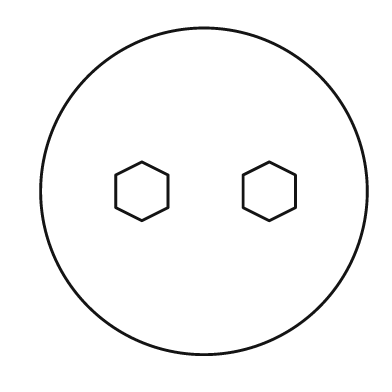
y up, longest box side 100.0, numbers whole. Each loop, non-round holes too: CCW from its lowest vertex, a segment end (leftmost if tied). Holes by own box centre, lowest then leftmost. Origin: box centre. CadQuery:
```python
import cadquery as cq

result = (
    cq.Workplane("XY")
    .moveTo(0.0, 0.0)
    .circle(50.0)
    .moveTo(-19.0, -9.0)
    .lineTo(-11.0, -5.0)
    .lineTo(-11.0, 5.0)
    .lineTo(-19.0, 9.0)
    .lineTo(-27.0, 5.0)
    .lineTo(-27.0, -5.0)
    .close()
    .moveTo(20.0, -9.0)
    .lineTo(28.0, -5.0)
    .lineTo(28.0, 5.0)
    .lineTo(20.0, 9.0)
    .lineTo(12.0, 5.0)
    .lineTo(12.0, -5.0)
    .close()
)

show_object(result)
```